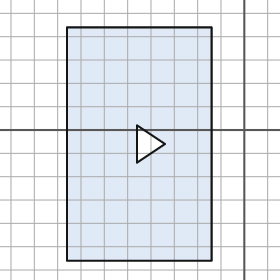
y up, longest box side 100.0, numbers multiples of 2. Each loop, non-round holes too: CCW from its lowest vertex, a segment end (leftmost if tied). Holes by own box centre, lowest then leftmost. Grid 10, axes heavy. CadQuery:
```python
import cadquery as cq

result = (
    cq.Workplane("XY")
    .moveTo(-76.0, -56.0)
    .lineTo(-14.0, -56.0)
    .lineTo(-14.0, 44.0)
    .lineTo(-76.0, 44.0)
    .close()
    .moveTo(-46.0, -14.0)
    .lineTo(-34.0, -6.0)
    .lineTo(-46.0, 2.0)
    .close()
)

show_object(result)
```